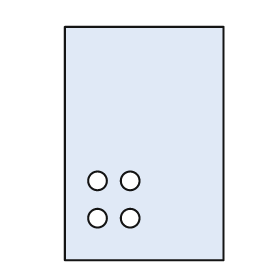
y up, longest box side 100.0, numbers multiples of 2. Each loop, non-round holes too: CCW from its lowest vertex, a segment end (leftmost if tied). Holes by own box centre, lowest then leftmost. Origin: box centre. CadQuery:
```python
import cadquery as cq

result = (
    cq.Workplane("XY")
    .moveTo(-34.0, -50.0)
    .lineTo(34.0, -50.0)
    .lineTo(34.0, 50.0)
    .lineTo(-34.0, 50.0)
    .close()
    .moveTo(-20.0, -32.0)
    .circle(4.0)
    .moveTo(-6.0, -32.0)
    .circle(4.0)
    .moveTo(-20.0, -16.0)
    .circle(4.0)
    .moveTo(-6.0, -16.0)
    .circle(4.0)
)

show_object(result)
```